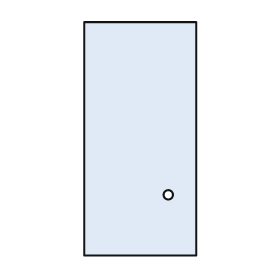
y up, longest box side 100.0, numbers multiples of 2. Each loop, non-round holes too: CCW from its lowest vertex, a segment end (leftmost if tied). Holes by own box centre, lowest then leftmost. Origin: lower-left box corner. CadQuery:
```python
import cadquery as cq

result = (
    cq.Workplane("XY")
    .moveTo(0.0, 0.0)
    .lineTo(48.0, 0.0)
    .lineTo(48.0, 100.0)
    .lineTo(0.0, 100.0)
    .close()
    .moveTo(36.0, 26.0)
    .circle(2.0)
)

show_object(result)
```